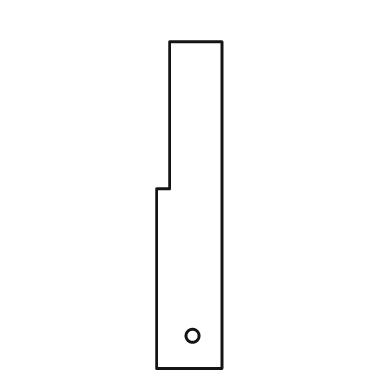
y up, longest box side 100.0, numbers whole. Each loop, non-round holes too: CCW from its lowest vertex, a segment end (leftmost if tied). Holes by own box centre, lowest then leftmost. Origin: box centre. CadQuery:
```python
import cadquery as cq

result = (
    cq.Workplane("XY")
    .moveTo(-10.0, -50.0)
    .lineTo(10.0, -50.0)
    .lineTo(10.0, 50.0)
    .lineTo(-6.0, 50.0)
    .lineTo(-6.0, 5.0)
    .lineTo(-10.0, 5.0)
    .close()
    .moveTo(1.0, -40.0)
    .circle(2.0)
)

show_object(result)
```